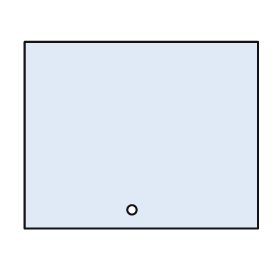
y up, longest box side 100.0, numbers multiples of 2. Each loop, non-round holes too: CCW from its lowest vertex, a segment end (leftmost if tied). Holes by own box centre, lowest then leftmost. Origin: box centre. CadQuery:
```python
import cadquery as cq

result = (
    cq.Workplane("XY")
    .moveTo(-50.0, -40.0)
    .lineTo(50.0, -40.0)
    .lineTo(50.0, 40.0)
    .lineTo(-50.0, 40.0)
    .close()
    .moveTo(-4.0, -32.0)
    .circle(2.0)
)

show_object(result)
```